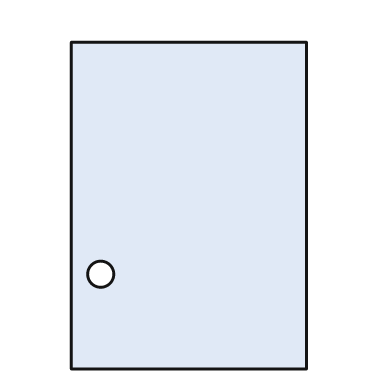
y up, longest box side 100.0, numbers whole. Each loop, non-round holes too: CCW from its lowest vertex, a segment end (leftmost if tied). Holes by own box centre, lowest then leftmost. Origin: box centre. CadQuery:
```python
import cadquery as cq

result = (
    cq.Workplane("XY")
    .moveTo(-36.0, -50.0)
    .lineTo(36.0, -50.0)
    .lineTo(36.0, 50.0)
    .lineTo(-36.0, 50.0)
    .close()
    .moveTo(-27.0, -21.0)
    .circle(4.0)
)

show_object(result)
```